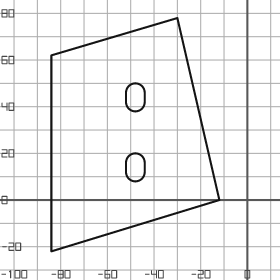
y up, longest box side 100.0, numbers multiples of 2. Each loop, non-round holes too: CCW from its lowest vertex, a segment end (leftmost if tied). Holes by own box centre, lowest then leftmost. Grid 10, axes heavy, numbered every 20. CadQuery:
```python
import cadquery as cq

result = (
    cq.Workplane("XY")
    .moveTo(-84.0, -22.0)
    .lineTo(-12.0, 0.0)
    .lineTo(-30.0, 78.0)
    .lineTo(-84.0, 62.0)
    .close()
    .moveTo(-52.0, 12.0)
    .threePointArc((-48.0, 8.0), (-44.0, 12.0))
    .lineTo(-44.0, 16.0)
    .threePointArc((-48.0, 20.0), (-52.0, 16.0))
    .close()
    .moveTo(-52.0, 42.0)
    .threePointArc((-48.0, 38.0), (-44.0, 42.0))
    .lineTo(-44.0, 46.0)
    .threePointArc((-48.0, 50.0), (-52.0, 46.0))
    .close()
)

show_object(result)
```